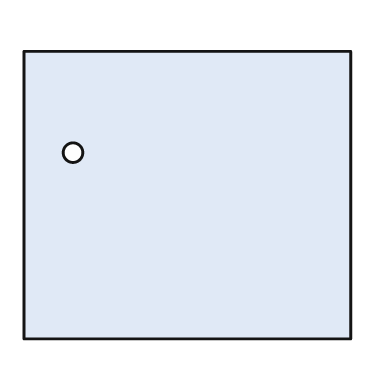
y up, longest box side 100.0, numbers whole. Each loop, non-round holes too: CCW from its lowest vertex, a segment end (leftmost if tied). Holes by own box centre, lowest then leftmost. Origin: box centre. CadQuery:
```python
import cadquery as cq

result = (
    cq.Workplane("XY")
    .moveTo(-50.0, -44.0)
    .lineTo(50.0, -44.0)
    .lineTo(50.0, 44.0)
    .lineTo(-50.0, 44.0)
    .close()
    .moveTo(-35.0, 13.0)
    .circle(3.0)
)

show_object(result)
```